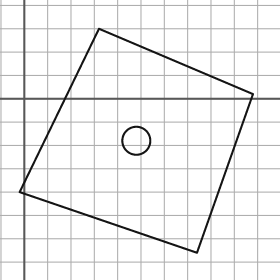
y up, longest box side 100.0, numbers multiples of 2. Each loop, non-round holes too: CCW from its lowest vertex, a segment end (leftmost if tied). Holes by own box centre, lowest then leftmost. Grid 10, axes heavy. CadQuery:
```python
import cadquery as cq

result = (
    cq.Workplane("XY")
    .moveTo(74.0, -66.0)
    .lineTo(98.0, 2.0)
    .lineTo(32.0, 30.0)
    .lineTo(-2.0, -40.0)
    .close()
    .moveTo(48.0, -18.0)
    .circle(6.0)
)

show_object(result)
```